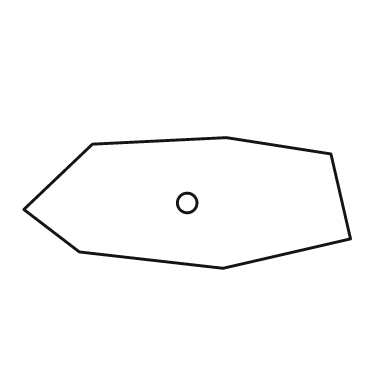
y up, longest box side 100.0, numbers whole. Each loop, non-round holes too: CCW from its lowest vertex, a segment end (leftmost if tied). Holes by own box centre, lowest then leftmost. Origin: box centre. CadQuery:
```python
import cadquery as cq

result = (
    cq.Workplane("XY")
    .moveTo(11.0, -20.0)
    .lineTo(50.0, -11.0)
    .lineTo(44.0, 15.0)
    .lineTo(12.0, 20.0)
    .lineTo(-29.0, 18.0)
    .lineTo(-50.0, -2.0)
    .lineTo(-33.0, -15.0)
    .close()
    .moveTo(0.0, 0.0)
    .circle(3.0)
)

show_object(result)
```